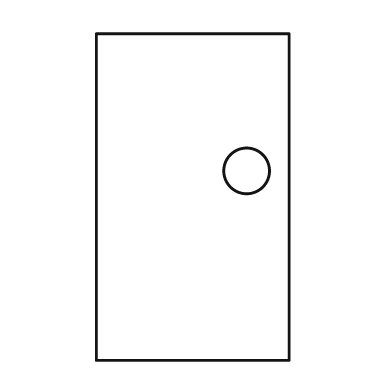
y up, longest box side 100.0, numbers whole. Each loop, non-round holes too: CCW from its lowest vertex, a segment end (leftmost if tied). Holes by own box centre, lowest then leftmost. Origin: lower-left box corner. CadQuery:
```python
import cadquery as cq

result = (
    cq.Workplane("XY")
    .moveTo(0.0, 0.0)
    .lineTo(59.0, 0.0)
    .lineTo(59.0, 100.0)
    .lineTo(0.0, 100.0)
    .close()
    .moveTo(46.0, 58.0)
    .circle(7.0)
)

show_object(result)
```